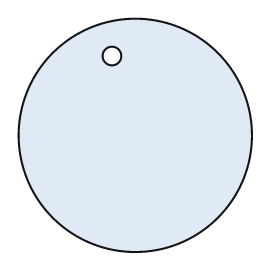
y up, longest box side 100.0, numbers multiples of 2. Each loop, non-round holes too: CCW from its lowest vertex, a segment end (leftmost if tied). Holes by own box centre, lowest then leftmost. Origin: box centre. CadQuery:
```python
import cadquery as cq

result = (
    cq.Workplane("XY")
    .moveTo(0.0, 0.0)
    .circle(50.0)
    .moveTo(-10.0, 34.0)
    .circle(4.0)
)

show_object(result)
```